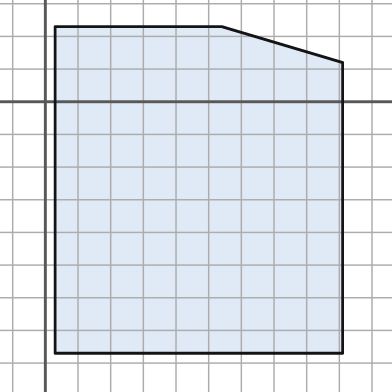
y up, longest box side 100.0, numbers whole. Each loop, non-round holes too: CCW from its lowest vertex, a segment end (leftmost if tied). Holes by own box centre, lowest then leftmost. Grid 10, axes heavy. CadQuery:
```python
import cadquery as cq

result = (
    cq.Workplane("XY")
    .moveTo(3.0, -77.0)
    .lineTo(91.0, -77.0)
    .lineTo(91.0, 12.0)
    .lineTo(54.0, 23.0)
    .lineTo(3.0, 23.0)
    .close()
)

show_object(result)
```